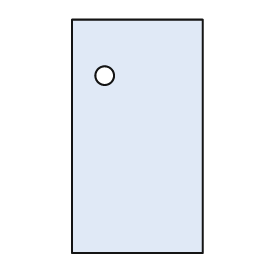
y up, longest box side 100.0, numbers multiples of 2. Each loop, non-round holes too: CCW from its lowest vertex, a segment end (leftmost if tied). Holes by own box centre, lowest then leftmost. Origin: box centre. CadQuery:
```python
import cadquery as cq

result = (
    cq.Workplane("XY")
    .moveTo(-28.0, -50.0)
    .lineTo(28.0, -50.0)
    .lineTo(28.0, 50.0)
    .lineTo(-28.0, 50.0)
    .close()
    .moveTo(-14.0, 26.0)
    .circle(4.0)
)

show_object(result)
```